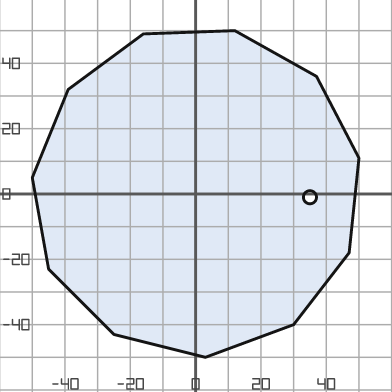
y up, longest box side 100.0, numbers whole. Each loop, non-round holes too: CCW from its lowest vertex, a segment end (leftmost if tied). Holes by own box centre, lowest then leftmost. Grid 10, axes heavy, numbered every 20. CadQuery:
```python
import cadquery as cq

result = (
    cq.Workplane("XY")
    .moveTo(3.0, -50.0)
    .lineTo(30.0, -40.0)
    .lineTo(47.0, -18.0)
    .lineTo(50.0, 11.0)
    .lineTo(37.0, 36.0)
    .lineTo(12.0, 50.0)
    .lineTo(-16.0, 49.0)
    .lineTo(-39.0, 32.0)
    .lineTo(-50.0, 5.0)
    .lineTo(-45.0, -23.0)
    .lineTo(-25.0, -43.0)
    .close()
    .moveTo(35.0, -1.0)
    .circle(2.0)
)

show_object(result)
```